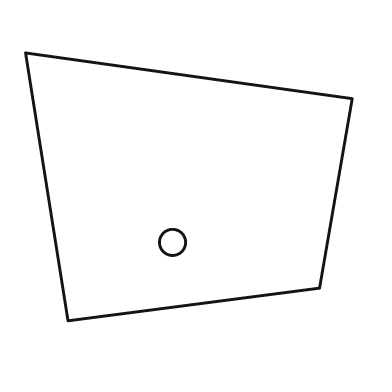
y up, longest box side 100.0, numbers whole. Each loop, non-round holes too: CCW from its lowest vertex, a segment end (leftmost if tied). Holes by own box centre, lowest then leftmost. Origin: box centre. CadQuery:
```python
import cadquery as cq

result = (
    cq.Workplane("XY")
    .moveTo(-37.0, -41.0)
    .lineTo(40.0, -31.0)
    .lineTo(50.0, 27.0)
    .lineTo(-50.0, 41.0)
    .close()
    .moveTo(-5.0, -17.0)
    .circle(4.0)
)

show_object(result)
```